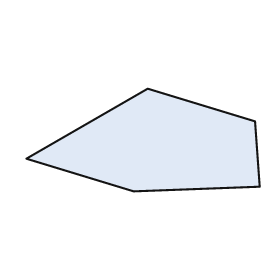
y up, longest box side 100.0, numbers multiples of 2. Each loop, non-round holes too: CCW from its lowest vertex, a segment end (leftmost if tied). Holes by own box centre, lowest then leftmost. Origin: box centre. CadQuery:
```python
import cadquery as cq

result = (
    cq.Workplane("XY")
    .moveTo(-4.0, -22.0)
    .lineTo(50.0, -20.0)
    .lineTo(48.0, 8.0)
    .lineTo(2.0, 22.0)
    .lineTo(-50.0, -8.0)
    .close()
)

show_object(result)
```